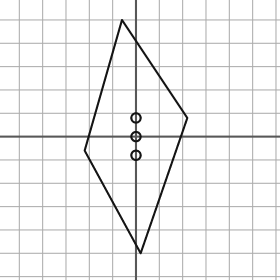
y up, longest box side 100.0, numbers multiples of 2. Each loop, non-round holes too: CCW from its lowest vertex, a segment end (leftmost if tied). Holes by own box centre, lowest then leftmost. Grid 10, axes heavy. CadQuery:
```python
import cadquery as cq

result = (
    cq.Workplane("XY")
    .moveTo(2.0, -50.0)
    .lineTo(22.0, 8.0)
    .lineTo(-6.0, 50.0)
    .lineTo(-22.0, -6.0)
    .close()
    .moveTo(0.0, -8.0)
    .circle(2.0)
    .moveTo(0.0, 0.0)
    .circle(2.0)
    .moveTo(0.0, 8.0)
    .circle(2.0)
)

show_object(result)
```